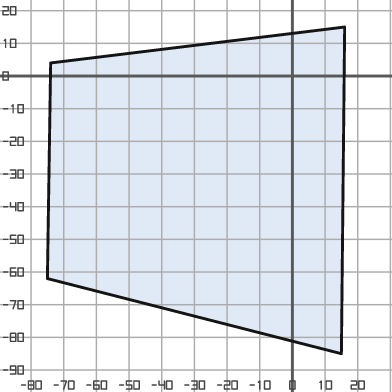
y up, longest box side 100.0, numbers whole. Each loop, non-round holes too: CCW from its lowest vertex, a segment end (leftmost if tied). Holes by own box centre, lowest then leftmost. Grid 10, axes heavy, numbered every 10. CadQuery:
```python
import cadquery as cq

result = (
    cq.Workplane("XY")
    .moveTo(15.0, -85.0)
    .lineTo(16.0, 15.0)
    .lineTo(-74.0, 4.0)
    .lineTo(-75.0, -62.0)
    .close()
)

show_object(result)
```